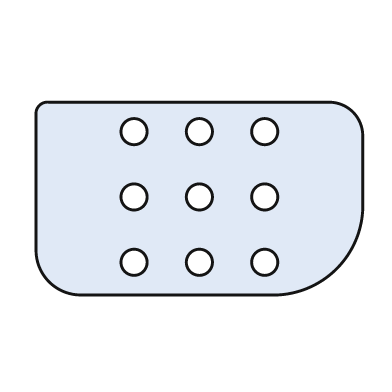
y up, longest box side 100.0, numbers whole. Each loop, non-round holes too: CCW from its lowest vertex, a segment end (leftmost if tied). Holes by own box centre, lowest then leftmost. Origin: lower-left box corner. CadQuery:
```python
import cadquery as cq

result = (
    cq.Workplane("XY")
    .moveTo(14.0, 0.0)
    .lineTo(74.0, 0.0)
    .threePointArc((92.0, 8.0), (100.0, 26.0))
    .lineTo(100.0, 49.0)
    .threePointArc((97.0, 56.0), (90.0, 59.0))
    .lineTo(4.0, 59.0)
    .threePointArc((1.0, 58.0), (0.0, 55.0))
    .lineTo(0.0, 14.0)
    .threePointArc((4.0, 4.0), (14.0, 0.0))
    .close()
    .moveTo(30.0, 10.0)
    .circle(4.0)
    .moveTo(50.0, 10.0)
    .circle(4.0)
    .moveTo(70.0, 10.0)
    .circle(4.0)
    .moveTo(30.0, 30.0)
    .circle(4.0)
    .moveTo(50.0, 30.0)
    .circle(4.0)
    .moveTo(70.0, 30.0)
    .circle(4.0)
    .moveTo(30.0, 50.0)
    .circle(4.0)
    .moveTo(50.0, 50.0)
    .circle(4.0)
    .moveTo(70.0, 50.0)
    .circle(4.0)
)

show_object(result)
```